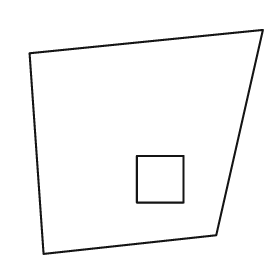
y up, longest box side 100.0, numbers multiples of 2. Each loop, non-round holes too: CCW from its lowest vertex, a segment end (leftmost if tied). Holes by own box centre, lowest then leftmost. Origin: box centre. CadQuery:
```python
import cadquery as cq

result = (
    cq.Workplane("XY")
    .moveTo(-44.0, -48.0)
    .lineTo(30.0, -40.0)
    .lineTo(50.0, 48.0)
    .lineTo(-50.0, 38.0)
    .close()
    .moveTo(-4.0, -26.0)
    .lineTo(16.0, -26.0)
    .lineTo(16.0, -6.0)
    .lineTo(-4.0, -6.0)
    .close()
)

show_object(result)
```